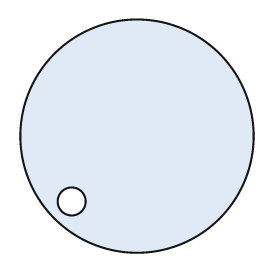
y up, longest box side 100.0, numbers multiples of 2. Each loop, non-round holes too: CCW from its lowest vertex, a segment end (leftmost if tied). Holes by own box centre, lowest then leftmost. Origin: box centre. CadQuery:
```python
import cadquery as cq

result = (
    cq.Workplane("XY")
    .moveTo(0.0, 0.0)
    .circle(50.0)
    .moveTo(-28.0, -28.0)
    .circle(6.0)
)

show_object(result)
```